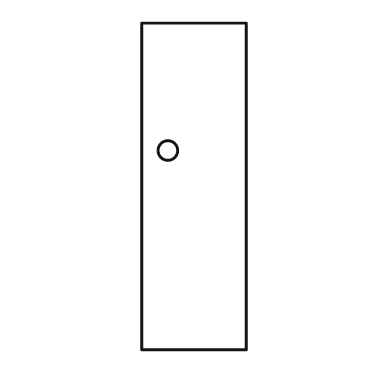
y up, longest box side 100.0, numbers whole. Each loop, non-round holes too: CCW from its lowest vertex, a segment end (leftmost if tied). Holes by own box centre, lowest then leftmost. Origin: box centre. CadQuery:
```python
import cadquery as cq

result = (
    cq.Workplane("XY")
    .moveTo(-16.0, -50.0)
    .lineTo(16.0, -50.0)
    .lineTo(16.0, 50.0)
    .lineTo(-16.0, 50.0)
    .close()
    .moveTo(-8.0, 11.0)
    .circle(3.0)
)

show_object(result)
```